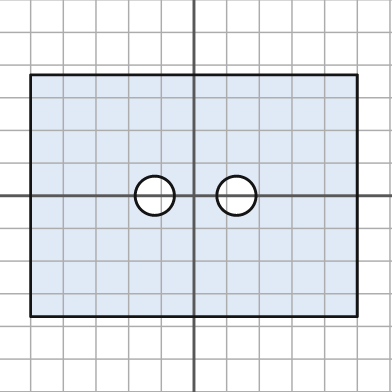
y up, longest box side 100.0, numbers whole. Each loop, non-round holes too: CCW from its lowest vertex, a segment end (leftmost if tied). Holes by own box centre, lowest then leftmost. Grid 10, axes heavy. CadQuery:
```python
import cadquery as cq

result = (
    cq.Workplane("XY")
    .moveTo(-50.0, -37.0)
    .lineTo(50.0, -37.0)
    .lineTo(50.0, 37.0)
    .lineTo(-50.0, 37.0)
    .close()
    .moveTo(-12.0, 0.0)
    .circle(6.0)
    .moveTo(13.0, 0.0)
    .circle(6.0)
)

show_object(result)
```